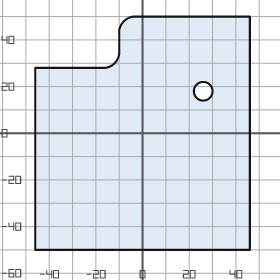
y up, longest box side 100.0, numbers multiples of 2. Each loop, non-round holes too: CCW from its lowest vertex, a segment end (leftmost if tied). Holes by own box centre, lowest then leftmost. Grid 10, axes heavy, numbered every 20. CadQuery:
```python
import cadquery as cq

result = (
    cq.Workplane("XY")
    .moveTo(-46.0, -50.0)
    .lineTo(46.0, -50.0)
    .lineTo(46.0, 50.0)
    .lineTo(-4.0, 50.0)
    .threePointArc((-8.0, 48.0), (-10.0, 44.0))
    .lineTo(-10.0, 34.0)
    .threePointArc((-12.0, 30.0), (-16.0, 28.0))
    .lineTo(-46.0, 28.0)
    .close()
    .moveTo(26.0, 18.0)
    .circle(4.0)
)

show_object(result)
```